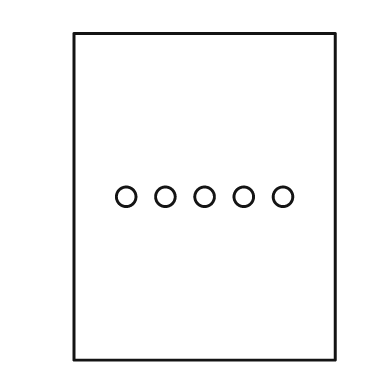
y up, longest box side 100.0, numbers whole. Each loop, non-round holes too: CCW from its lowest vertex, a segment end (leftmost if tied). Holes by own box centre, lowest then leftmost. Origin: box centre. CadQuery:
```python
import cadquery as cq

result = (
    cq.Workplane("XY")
    .moveTo(-40.0, -50.0)
    .lineTo(40.0, -50.0)
    .lineTo(40.0, 50.0)
    .lineTo(-40.0, 50.0)
    .close()
    .moveTo(-24.0, 0.0)
    .circle(3.0)
    .moveTo(-12.0, 0.0)
    .circle(3.0)
    .moveTo(0.0, 0.0)
    .circle(3.0)
    .moveTo(12.0, 0.0)
    .circle(3.0)
    .moveTo(24.0, 0.0)
    .circle(3.0)
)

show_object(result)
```